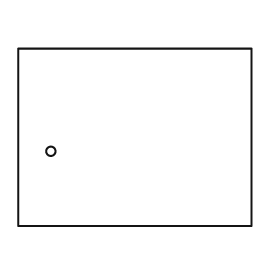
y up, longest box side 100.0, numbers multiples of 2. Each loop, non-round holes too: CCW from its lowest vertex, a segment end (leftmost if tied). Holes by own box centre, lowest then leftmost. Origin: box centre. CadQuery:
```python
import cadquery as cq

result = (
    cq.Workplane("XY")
    .moveTo(-50.0, -38.0)
    .lineTo(50.0, -38.0)
    .lineTo(50.0, 38.0)
    .lineTo(-50.0, 38.0)
    .close()
    .moveTo(-36.0, -6.0)
    .circle(2.0)
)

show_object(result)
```